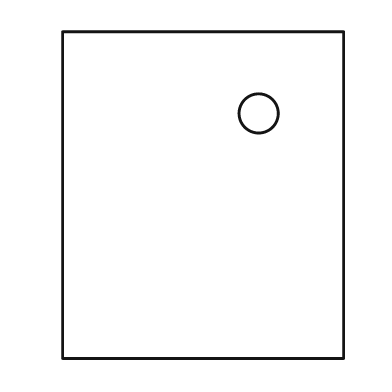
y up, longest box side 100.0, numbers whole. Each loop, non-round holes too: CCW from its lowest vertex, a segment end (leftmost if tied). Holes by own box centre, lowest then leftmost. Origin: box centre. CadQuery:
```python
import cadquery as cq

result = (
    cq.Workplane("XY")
    .moveTo(-43.0, -50.0)
    .lineTo(43.0, -50.0)
    .lineTo(43.0, 50.0)
    .lineTo(-43.0, 50.0)
    .close()
    .moveTo(17.0, 25.0)
    .circle(6.0)
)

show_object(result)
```